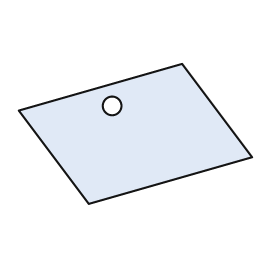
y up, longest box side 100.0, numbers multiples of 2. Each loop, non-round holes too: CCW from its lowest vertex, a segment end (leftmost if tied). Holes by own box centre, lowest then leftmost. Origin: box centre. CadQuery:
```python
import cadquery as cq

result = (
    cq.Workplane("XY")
    .moveTo(-20.0, -30.0)
    .lineTo(50.0, -10.0)
    .lineTo(20.0, 30.0)
    .lineTo(-50.0, 10.0)
    .close()
    .moveTo(-10.0, 12.0)
    .circle(4.0)
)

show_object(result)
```